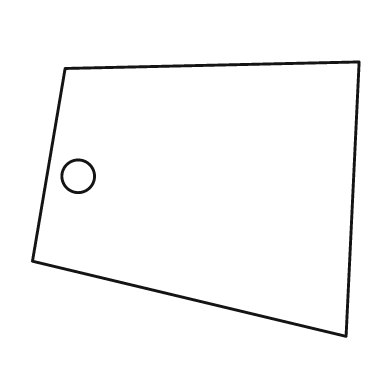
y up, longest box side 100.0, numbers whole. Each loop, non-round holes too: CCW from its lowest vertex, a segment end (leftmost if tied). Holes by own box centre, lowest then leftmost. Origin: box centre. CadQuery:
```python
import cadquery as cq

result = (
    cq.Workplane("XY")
    .moveTo(46.0, -42.0)
    .lineTo(50.0, 42.0)
    .lineTo(-40.0, 40.0)
    .lineTo(-50.0, -19.0)
    .close()
    .moveTo(-36.0, 7.0)
    .circle(5.0)
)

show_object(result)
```